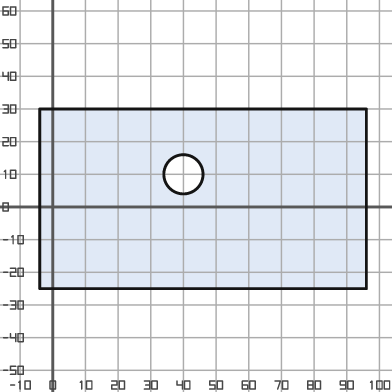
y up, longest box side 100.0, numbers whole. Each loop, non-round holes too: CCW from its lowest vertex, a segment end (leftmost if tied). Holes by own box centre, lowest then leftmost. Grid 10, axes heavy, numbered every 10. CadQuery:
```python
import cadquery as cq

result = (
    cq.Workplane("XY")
    .moveTo(-4.0, -25.0)
    .lineTo(96.0, -25.0)
    .lineTo(96.0, 30.0)
    .lineTo(-4.0, 30.0)
    .close()
    .moveTo(40.0, 10.0)
    .circle(6.0)
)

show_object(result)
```